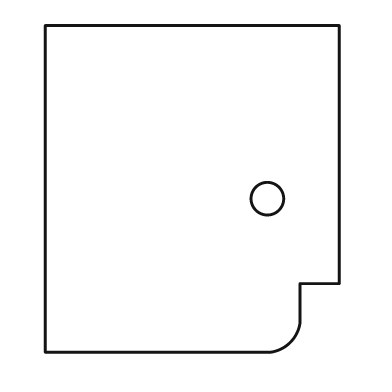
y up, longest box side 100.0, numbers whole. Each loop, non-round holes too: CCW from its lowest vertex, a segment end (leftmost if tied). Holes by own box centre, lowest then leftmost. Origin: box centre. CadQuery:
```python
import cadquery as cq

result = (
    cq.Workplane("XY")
    .moveTo(-45.0, -50.0)
    .lineTo(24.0, -50.0)
    .threePointArc((30.0, -47.0), (33.0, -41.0))
    .lineTo(33.0, -29.0)
    .lineTo(45.0, -29.0)
    .lineTo(45.0, 50.0)
    .lineTo(-45.0, 50.0)
    .close()
    .moveTo(23.0, -3.0)
    .circle(5.0)
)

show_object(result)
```